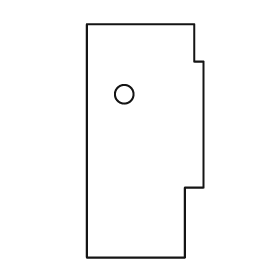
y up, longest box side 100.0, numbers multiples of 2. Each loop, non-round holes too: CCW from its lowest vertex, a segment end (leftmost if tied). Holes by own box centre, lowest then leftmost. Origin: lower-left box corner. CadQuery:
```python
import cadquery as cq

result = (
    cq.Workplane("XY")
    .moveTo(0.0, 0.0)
    .lineTo(42.0, 0.0)
    .lineTo(42.0, 30.0)
    .lineTo(50.0, 30.0)
    .lineTo(50.0, 84.0)
    .lineTo(46.0, 84.0)
    .lineTo(46.0, 100.0)
    .lineTo(0.0, 100.0)
    .close()
    .moveTo(16.0, 70.0)
    .circle(4.0)
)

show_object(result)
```